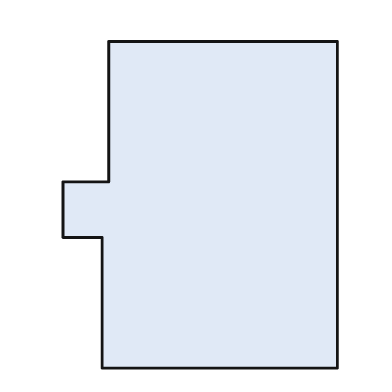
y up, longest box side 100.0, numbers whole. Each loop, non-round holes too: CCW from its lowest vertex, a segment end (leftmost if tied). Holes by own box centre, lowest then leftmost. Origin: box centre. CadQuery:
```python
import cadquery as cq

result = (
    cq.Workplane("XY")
    .moveTo(-30.0, -50.0)
    .lineTo(42.0, -50.0)
    .lineTo(42.0, 50.0)
    .lineTo(-28.0, 50.0)
    .lineTo(-28.0, 7.0)
    .lineTo(-42.0, 7.0)
    .lineTo(-42.0, -10.0)
    .lineTo(-30.0, -10.0)
    .close()
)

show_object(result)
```